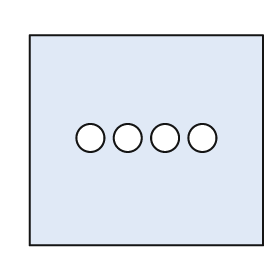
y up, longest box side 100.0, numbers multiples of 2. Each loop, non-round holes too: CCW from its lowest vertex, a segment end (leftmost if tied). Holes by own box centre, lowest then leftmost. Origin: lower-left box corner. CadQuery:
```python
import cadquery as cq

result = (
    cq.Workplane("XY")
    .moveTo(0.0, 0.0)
    .lineTo(100.0, 0.0)
    .lineTo(100.0, 90.0)
    .lineTo(0.0, 90.0)
    .close()
    .moveTo(26.0, 46.0)
    .circle(6.0)
    .moveTo(42.0, 46.0)
    .circle(6.0)
    .moveTo(58.0, 46.0)
    .circle(6.0)
    .moveTo(74.0, 46.0)
    .circle(6.0)
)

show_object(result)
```